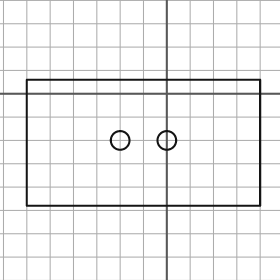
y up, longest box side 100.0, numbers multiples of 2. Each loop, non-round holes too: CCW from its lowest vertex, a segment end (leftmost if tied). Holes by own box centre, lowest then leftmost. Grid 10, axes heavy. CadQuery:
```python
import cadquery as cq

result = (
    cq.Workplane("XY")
    .moveTo(-60.0, -48.0)
    .lineTo(40.0, -48.0)
    .lineTo(40.0, 6.0)
    .lineTo(-60.0, 6.0)
    .close()
    .moveTo(-20.0, -20.0)
    .circle(4.0)
    .moveTo(0.0, -20.0)
    .circle(4.0)
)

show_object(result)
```